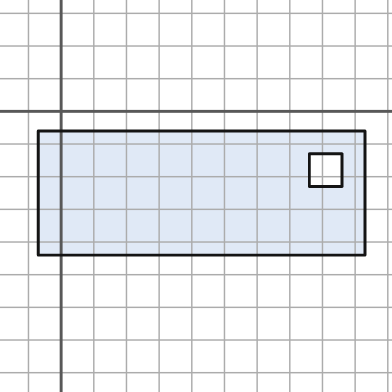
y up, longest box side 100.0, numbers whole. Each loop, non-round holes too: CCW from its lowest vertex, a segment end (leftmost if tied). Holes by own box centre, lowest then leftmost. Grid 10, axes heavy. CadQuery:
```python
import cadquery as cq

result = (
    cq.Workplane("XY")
    .moveTo(-7.0, -44.0)
    .lineTo(93.0, -44.0)
    .lineTo(93.0, -6.0)
    .lineTo(-7.0, -6.0)
    .close()
    .moveTo(76.0, -23.0)
    .lineTo(86.0, -23.0)
    .lineTo(86.0, -13.0)
    .lineTo(76.0, -13.0)
    .close()
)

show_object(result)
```